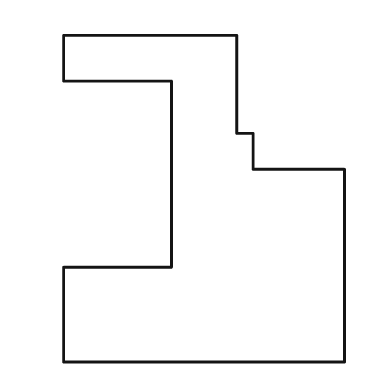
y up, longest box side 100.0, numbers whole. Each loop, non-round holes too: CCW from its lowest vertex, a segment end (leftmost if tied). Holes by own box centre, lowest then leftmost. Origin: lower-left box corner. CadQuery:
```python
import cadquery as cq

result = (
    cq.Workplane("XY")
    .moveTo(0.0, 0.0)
    .lineTo(86.0, 0.0)
    .lineTo(86.0, 59.0)
    .lineTo(58.0, 59.0)
    .lineTo(58.0, 70.0)
    .lineTo(53.0, 70.0)
    .lineTo(53.0, 100.0)
    .lineTo(0.0, 100.0)
    .lineTo(0.0, 86.0)
    .lineTo(33.0, 86.0)
    .lineTo(33.0, 29.0)
    .lineTo(0.0, 29.0)
    .close()
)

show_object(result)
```